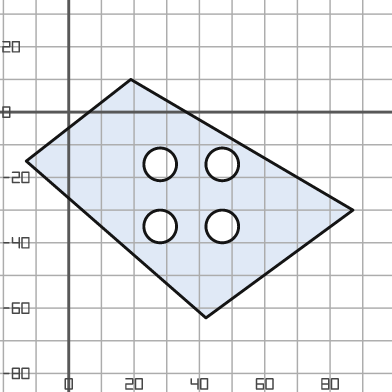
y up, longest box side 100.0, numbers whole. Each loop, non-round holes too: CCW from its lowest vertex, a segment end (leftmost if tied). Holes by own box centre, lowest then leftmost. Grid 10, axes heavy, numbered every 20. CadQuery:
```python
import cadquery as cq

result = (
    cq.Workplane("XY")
    .moveTo(42.0, -63.0)
    .lineTo(87.0, -30.0)
    .lineTo(19.0, 10.0)
    .lineTo(-13.0, -15.0)
    .close()
    .moveTo(28.0, -35.0)
    .circle(5.0)
    .moveTo(47.0, -35.0)
    .circle(5.0)
    .moveTo(28.0, -16.0)
    .circle(5.0)
    .moveTo(47.0, -16.0)
    .circle(5.0)
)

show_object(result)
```